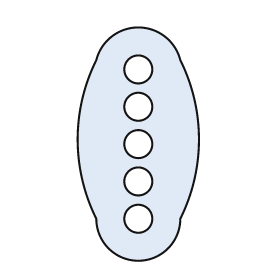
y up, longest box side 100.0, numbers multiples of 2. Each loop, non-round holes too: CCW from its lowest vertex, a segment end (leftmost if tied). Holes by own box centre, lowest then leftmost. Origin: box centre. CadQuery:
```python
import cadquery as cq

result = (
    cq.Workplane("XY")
    .moveTo(-18.0, -32.0)
    .threePointArc((0.0, -50.0), (18.0, -32.0))
    .threePointArc((26.0, 2.0), (18.0, 36.0))
    .threePointArc((0.0, 50.0), (-18.0, 36.0))
    .threePointArc((-26.0, 2.0), (-18.0, -32.0))
    .close()
    .moveTo(0.0, -32.0)
    .circle(6.0)
    .moveTo(0.0, -16.0)
    .circle(6.0)
    .moveTo(0.0, 0.0)
    .circle(6.0)
    .moveTo(0.0, 16.0)
    .circle(6.0)
    .moveTo(0.0, 32.0)
    .circle(6.0)
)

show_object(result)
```